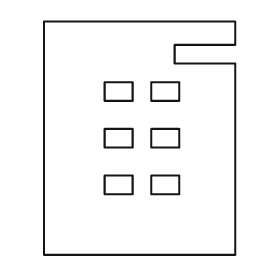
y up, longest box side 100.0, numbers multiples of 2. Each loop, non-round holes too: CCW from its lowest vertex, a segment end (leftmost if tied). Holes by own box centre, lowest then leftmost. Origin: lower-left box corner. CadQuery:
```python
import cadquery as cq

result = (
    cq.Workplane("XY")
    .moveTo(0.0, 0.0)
    .lineTo(82.0, 0.0)
    .lineTo(82.0, 82.0)
    .lineTo(56.0, 82.0)
    .lineTo(56.0, 90.0)
    .lineTo(82.0, 90.0)
    .lineTo(82.0, 100.0)
    .lineTo(0.0, 100.0)
    .close()
    .moveTo(26.0, 26.0)
    .lineTo(38.0, 26.0)
    .lineTo(38.0, 34.0)
    .lineTo(26.0, 34.0)
    .close()
    .moveTo(46.0, 26.0)
    .lineTo(58.0, 26.0)
    .lineTo(58.0, 34.0)
    .lineTo(46.0, 34.0)
    .close()
    .moveTo(26.0, 46.0)
    .lineTo(38.0, 46.0)
    .lineTo(38.0, 54.0)
    .lineTo(26.0, 54.0)
    .close()
    .moveTo(46.0, 46.0)
    .lineTo(58.0, 46.0)
    .lineTo(58.0, 54.0)
    .lineTo(46.0, 54.0)
    .close()
    .moveTo(26.0, 66.0)
    .lineTo(38.0, 66.0)
    .lineTo(38.0, 74.0)
    .lineTo(26.0, 74.0)
    .close()
    .moveTo(46.0, 66.0)
    .lineTo(58.0, 66.0)
    .lineTo(58.0, 74.0)
    .lineTo(46.0, 74.0)
    .close()
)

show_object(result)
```